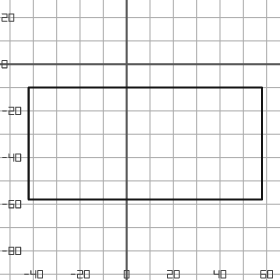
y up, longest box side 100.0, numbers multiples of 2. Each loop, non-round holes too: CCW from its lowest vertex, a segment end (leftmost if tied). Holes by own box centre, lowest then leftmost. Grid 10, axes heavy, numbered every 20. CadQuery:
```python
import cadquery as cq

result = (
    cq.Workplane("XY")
    .moveTo(-42.0, -58.0)
    .lineTo(58.0, -58.0)
    .lineTo(58.0, -10.0)
    .lineTo(-42.0, -10.0)
    .close()
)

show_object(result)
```